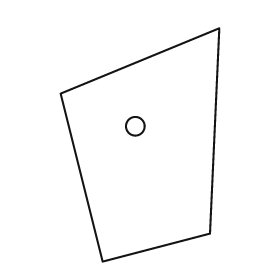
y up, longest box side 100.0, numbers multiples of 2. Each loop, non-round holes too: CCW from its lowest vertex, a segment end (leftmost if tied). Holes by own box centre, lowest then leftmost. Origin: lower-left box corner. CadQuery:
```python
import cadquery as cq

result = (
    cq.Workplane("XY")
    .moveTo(18.0, 0.0)
    .lineTo(64.0, 12.0)
    .lineTo(68.0, 100.0)
    .lineTo(0.0, 72.0)
    .close()
    .moveTo(32.0, 58.0)
    .circle(4.0)
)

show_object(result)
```